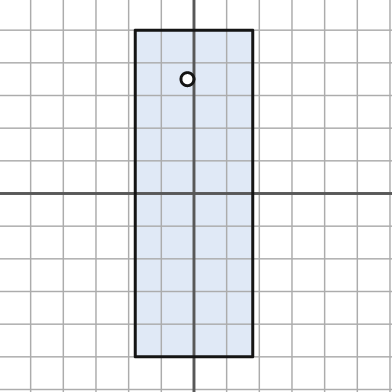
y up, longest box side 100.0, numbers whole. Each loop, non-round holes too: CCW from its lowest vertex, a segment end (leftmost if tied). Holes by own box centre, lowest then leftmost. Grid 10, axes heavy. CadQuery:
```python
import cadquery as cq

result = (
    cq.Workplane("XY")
    .moveTo(-18.0, -50.0)
    .lineTo(18.0, -50.0)
    .lineTo(18.0, 50.0)
    .lineTo(-18.0, 50.0)
    .close()
    .moveTo(-2.0, 35.0)
    .circle(2.0)
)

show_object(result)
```